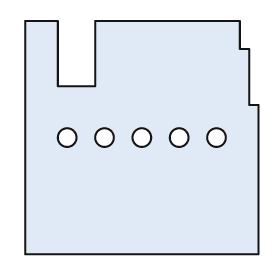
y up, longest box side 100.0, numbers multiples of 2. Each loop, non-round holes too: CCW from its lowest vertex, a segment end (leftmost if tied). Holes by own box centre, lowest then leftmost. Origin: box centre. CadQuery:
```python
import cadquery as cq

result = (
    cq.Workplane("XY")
    .moveTo(-50.0, -50.0)
    .lineTo(50.0, -50.0)
    .lineTo(50.0, 14.0)
    .lineTo(46.0, 14.0)
    .lineTo(46.0, 38.0)
    .lineTo(42.0, 38.0)
    .lineTo(42.0, 50.0)
    .lineTo(-20.0, 50.0)
    .lineTo(-20.0, 22.0)
    .lineTo(-36.0, 22.0)
    .lineTo(-36.0, 50.0)
    .lineTo(-50.0, 50.0)
    .close()
    .moveTo(-32.0, 0.0)
    .circle(4.0)
    .moveTo(-16.0, 0.0)
    .circle(4.0)
    .moveTo(0.0, 0.0)
    .circle(4.0)
    .moveTo(16.0, 0.0)
    .circle(4.0)
    .moveTo(32.0, 0.0)
    .circle(4.0)
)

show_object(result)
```